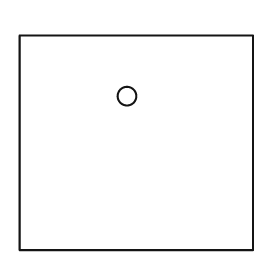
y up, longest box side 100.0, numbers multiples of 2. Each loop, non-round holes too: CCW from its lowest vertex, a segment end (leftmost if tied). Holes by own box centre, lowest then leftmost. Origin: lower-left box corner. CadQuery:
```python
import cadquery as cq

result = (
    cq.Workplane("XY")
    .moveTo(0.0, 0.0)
    .lineTo(100.0, 0.0)
    .lineTo(100.0, 92.0)
    .lineTo(0.0, 92.0)
    .close()
    .moveTo(46.0, 66.0)
    .circle(4.0)
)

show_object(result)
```